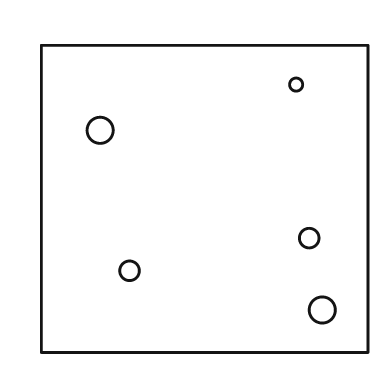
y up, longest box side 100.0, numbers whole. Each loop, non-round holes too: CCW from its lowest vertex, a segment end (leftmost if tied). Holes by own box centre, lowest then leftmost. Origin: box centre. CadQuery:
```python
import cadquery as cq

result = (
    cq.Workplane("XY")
    .moveTo(-50.0, -47.0)
    .lineTo(50.0, -47.0)
    .lineTo(50.0, 47.0)
    .lineTo(-50.0, 47.0)
    .close()
    .moveTo(36.0, -34.0)
    .circle(4.0)
    .moveTo(-23.0, -22.0)
    .circle(3.0)
    .moveTo(32.0, -12.0)
    .circle(3.0)
    .moveTo(-32.0, 21.0)
    .circle(4.0)
    .moveTo(28.0, 35.0)
    .circle(2.0)
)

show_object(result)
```